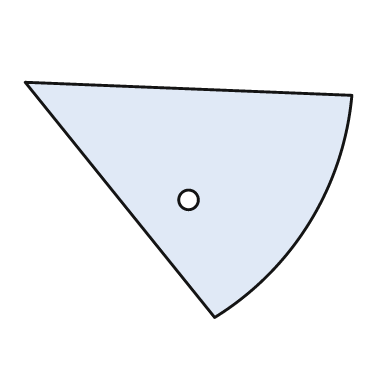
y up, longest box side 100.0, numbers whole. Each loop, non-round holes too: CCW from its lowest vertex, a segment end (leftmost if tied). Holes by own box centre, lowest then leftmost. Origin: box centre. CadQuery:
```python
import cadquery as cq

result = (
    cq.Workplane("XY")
    .moveTo(8.0, -36.0)
    .threePointArc((37.0, -7.0), (50.0, 32.0))
    .lineTo(-50.0, 36.0)
    .close()
    .moveTo(0.0, 0.0)
    .circle(3.0)
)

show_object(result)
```